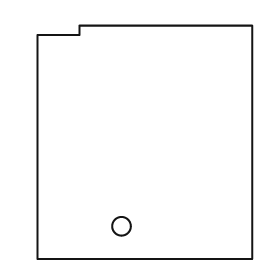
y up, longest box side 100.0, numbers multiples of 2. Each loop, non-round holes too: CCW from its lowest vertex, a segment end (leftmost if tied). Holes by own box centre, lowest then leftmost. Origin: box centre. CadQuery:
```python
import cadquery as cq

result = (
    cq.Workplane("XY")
    .moveTo(-46.0, -50.0)
    .lineTo(46.0, -50.0)
    .lineTo(46.0, 50.0)
    .lineTo(-28.0, 50.0)
    .lineTo(-28.0, 46.0)
    .lineTo(-46.0, 46.0)
    .close()
    .moveTo(-10.0, -36.0)
    .circle(4.0)
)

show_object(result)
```